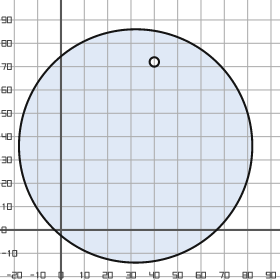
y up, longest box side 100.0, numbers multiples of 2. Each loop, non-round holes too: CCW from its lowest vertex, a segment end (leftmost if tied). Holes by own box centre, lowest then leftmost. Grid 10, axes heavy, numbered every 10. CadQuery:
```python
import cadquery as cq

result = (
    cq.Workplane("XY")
    .moveTo(32.0, 36.0)
    .circle(50.0)
    .moveTo(40.0, 72.0)
    .circle(2.0)
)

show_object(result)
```